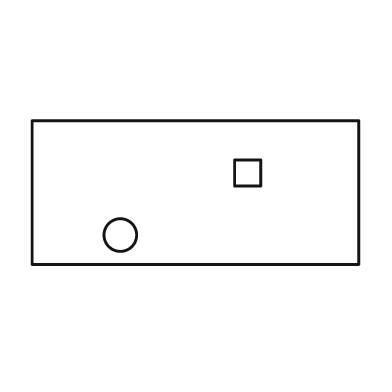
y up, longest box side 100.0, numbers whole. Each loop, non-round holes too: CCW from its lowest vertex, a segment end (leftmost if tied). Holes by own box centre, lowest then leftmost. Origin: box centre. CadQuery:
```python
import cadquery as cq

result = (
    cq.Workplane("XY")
    .moveTo(-50.0, -22.0)
    .lineTo(50.0, -22.0)
    .lineTo(50.0, 22.0)
    .lineTo(-50.0, 22.0)
    .close()
    .moveTo(-23.0, -13.0)
    .circle(5.0)
    .moveTo(12.0, 2.0)
    .lineTo(20.0, 2.0)
    .lineTo(20.0, 10.0)
    .lineTo(12.0, 10.0)
    .close()
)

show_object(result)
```